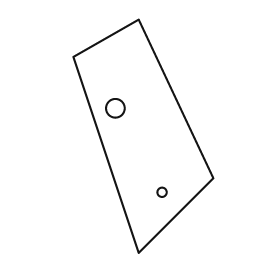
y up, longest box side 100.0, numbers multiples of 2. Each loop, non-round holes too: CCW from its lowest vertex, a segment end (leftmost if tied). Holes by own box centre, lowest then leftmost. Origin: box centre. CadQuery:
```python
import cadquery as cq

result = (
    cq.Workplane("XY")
    .moveTo(-2.0, -50.0)
    .lineTo(30.0, -18.0)
    .lineTo(-2.0, 50.0)
    .lineTo(-30.0, 34.0)
    .close()
    .moveTo(8.0, -24.0)
    .circle(2.0)
    .moveTo(-12.0, 12.0)
    .circle(4.0)
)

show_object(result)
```